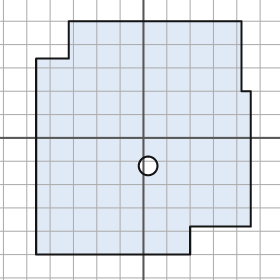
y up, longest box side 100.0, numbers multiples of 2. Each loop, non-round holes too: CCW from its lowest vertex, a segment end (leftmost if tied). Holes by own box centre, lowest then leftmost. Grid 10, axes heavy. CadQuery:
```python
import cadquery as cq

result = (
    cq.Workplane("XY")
    .moveTo(-46.0, -50.0)
    .lineTo(20.0, -50.0)
    .lineTo(20.0, -38.0)
    .lineTo(46.0, -38.0)
    .lineTo(46.0, 20.0)
    .lineTo(42.0, 20.0)
    .lineTo(42.0, 50.0)
    .lineTo(-32.0, 50.0)
    .lineTo(-32.0, 34.0)
    .lineTo(-46.0, 34.0)
    .close()
    .moveTo(2.0, -12.0)
    .circle(4.0)
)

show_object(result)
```